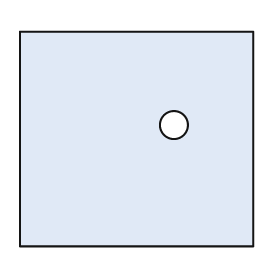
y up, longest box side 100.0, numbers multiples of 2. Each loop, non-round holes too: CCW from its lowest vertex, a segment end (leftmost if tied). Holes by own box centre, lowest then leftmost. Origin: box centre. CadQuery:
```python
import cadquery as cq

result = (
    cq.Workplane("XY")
    .moveTo(-50.0, -46.0)
    .lineTo(50.0, -46.0)
    .lineTo(50.0, 46.0)
    .lineTo(-50.0, 46.0)
    .close()
    .moveTo(16.0, 6.0)
    .circle(6.0)
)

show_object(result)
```